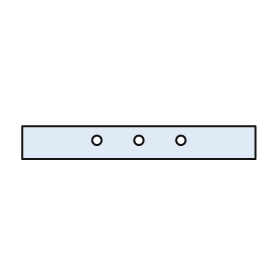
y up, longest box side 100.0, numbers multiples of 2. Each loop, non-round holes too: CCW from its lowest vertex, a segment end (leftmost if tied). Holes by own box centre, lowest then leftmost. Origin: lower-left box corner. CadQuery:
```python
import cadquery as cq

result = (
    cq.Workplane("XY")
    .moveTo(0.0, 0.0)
    .lineTo(100.0, 0.0)
    .lineTo(100.0, 14.0)
    .lineTo(0.0, 14.0)
    .close()
    .moveTo(32.0, 8.0)
    .circle(2.0)
    .moveTo(50.0, 8.0)
    .circle(2.0)
    .moveTo(68.0, 8.0)
    .circle(2.0)
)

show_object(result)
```